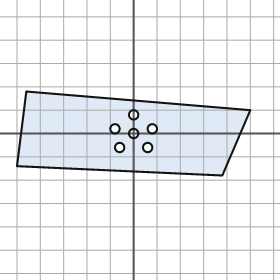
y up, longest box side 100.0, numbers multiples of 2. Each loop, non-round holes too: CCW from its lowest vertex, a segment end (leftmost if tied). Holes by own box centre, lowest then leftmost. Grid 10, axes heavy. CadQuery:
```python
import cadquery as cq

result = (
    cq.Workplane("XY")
    .moveTo(38.0, -18.0)
    .lineTo(50.0, 10.0)
    .lineTo(-46.0, 18.0)
    .lineTo(-50.0, -14.0)
    .close()
    .moveTo(-6.0, -6.0)
    .circle(2.0)
    .moveTo(6.0, -6.0)
    .circle(2.0)
    .moveTo(0.0, 0.0)
    .circle(2.0)
    .moveTo(-8.0, 2.0)
    .circle(2.0)
    .moveTo(8.0, 2.0)
    .circle(2.0)
    .moveTo(0.0, 8.0)
    .circle(2.0)
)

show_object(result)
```